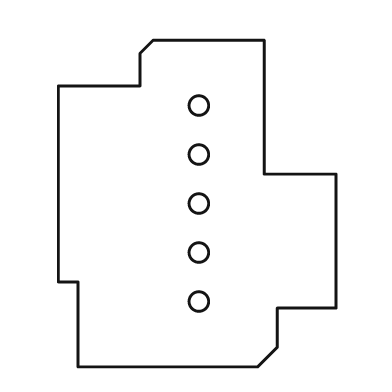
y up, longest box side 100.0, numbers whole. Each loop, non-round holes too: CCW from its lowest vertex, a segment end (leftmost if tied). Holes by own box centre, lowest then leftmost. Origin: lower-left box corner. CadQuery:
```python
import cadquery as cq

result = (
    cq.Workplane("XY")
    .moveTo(6.0, 0.0)
    .lineTo(61.0, 0.0)
    .lineTo(67.0, 6.0)
    .lineTo(67.0, 18.0)
    .lineTo(85.0, 18.0)
    .lineTo(85.0, 59.0)
    .lineTo(63.0, 59.0)
    .lineTo(63.0, 100.0)
    .lineTo(29.0, 100.0)
    .lineTo(25.0, 96.0)
    .lineTo(25.0, 86.0)
    .lineTo(0.0, 86.0)
    .lineTo(0.0, 26.0)
    .lineTo(6.0, 26.0)
    .close()
    .moveTo(43.0, 20.0)
    .circle(3.0)
    .moveTo(43.0, 35.0)
    .circle(3.0)
    .moveTo(43.0, 50.0)
    .circle(3.0)
    .moveTo(43.0, 65.0)
    .circle(3.0)
    .moveTo(43.0, 80.0)
    .circle(3.0)
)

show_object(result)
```